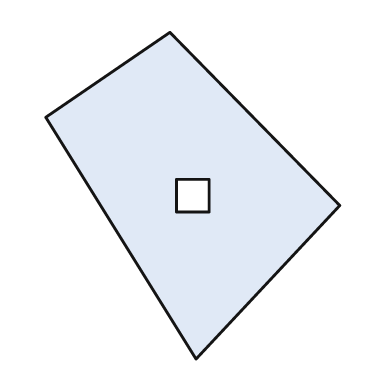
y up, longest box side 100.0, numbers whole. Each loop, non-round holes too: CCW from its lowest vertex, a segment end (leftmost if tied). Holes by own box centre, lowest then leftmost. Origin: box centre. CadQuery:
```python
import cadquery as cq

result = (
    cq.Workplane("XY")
    .moveTo(1.0, -50.0)
    .lineTo(45.0, -3.0)
    .lineTo(-7.0, 50.0)
    .lineTo(-45.0, 24.0)
    .close()
    .moveTo(-5.0, -5.0)
    .lineTo(5.0, -5.0)
    .lineTo(5.0, 5.0)
    .lineTo(-5.0, 5.0)
    .close()
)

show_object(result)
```